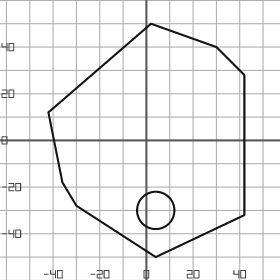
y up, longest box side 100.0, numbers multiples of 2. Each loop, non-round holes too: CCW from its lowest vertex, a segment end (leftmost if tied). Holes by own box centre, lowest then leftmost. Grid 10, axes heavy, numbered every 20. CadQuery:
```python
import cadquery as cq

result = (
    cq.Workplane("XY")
    .moveTo(4.0, -50.0)
    .lineTo(42.0, -32.0)
    .lineTo(42.0, 28.0)
    .lineTo(30.0, 40.0)
    .lineTo(2.0, 50.0)
    .lineTo(-42.0, 12.0)
    .lineTo(-36.0, -18.0)
    .lineTo(-30.0, -28.0)
    .close()
    .moveTo(4.0, -30.0)
    .circle(8.0)
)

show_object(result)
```